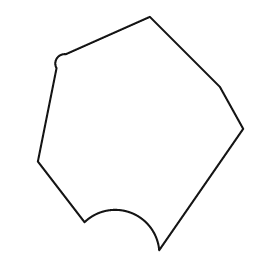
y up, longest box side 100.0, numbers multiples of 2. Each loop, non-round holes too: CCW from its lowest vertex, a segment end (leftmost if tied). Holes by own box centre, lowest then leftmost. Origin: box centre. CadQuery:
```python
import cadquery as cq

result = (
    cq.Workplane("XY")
    .moveTo(8.0, -50.0)
    .lineTo(44.0, 2.0)
    .lineTo(34.0, 20.0)
    .lineTo(4.0, 50.0)
    .lineTo(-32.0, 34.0)
    .threePointArc((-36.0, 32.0), (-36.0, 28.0))
    .lineTo(-44.0, -12.0)
    .lineTo(-24.0, -38.0)
    .threePointArc((-4.0, -34.0), (8.0, -50.0))
    .close()
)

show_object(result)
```